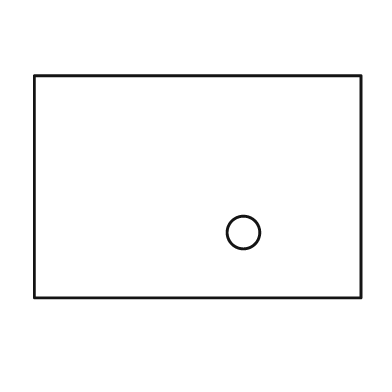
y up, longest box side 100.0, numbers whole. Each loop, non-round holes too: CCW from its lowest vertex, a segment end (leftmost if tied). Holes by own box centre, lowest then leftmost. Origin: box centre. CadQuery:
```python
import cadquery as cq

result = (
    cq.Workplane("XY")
    .moveTo(-50.0, -34.0)
    .lineTo(50.0, -34.0)
    .lineTo(50.0, 34.0)
    .lineTo(-50.0, 34.0)
    .close()
    .moveTo(14.0, -14.0)
    .circle(5.0)
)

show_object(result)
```